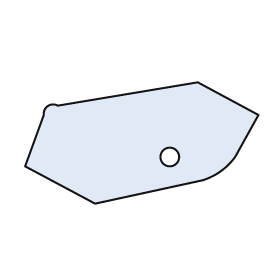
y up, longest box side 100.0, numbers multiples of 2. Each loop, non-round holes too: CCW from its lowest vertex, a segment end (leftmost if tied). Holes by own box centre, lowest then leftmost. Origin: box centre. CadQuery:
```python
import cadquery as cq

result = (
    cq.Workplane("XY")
    .moveTo(-20.0, -26.0)
    .lineTo(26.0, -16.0)
    .threePointArc((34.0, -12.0), (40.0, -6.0))
    .lineTo(50.0, 12.0)
    .lineTo(24.0, 26.0)
    .lineTo(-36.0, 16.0)
    .threePointArc((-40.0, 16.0), (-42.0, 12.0))
    .lineTo(-50.0, -10.0)
    .close()
    .moveTo(12.0, -6.0)
    .circle(4.0)
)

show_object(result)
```